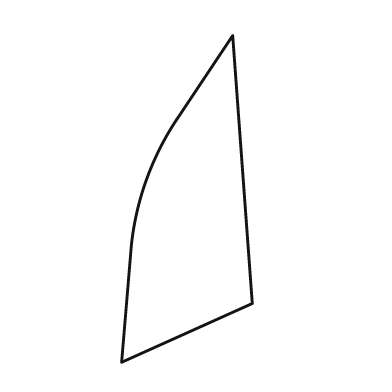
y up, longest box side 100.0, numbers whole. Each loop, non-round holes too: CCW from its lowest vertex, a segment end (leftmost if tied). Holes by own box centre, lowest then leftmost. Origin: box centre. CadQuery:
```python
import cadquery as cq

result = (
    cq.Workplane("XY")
    .moveTo(-20.0, -50.0)
    .lineTo(20.0, -32.0)
    .lineTo(14.0, 50.0)
    .lineTo(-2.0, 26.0)
    .threePointArc((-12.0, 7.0), (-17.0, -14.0))
    .close()
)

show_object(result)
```